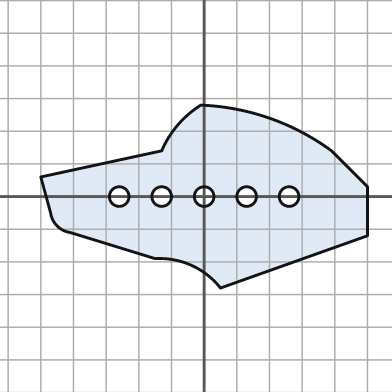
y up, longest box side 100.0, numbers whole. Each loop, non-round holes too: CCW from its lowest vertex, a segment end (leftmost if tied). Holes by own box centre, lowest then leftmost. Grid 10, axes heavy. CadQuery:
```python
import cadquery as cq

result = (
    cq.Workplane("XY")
    .moveTo(5.0, -28.0)
    .lineTo(50.0, -12.0)
    .lineTo(50.0, 3.0)
    .lineTo(39.0, 14.0)
    .threePointArc((20.0, 24.0), (-1.0, 28.0))
    .threePointArc((-8.0, 22.0), (-13.0, 14.0))
    .lineTo(-50.0, 6.0)
    .lineTo(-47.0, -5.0)
    .threePointArc((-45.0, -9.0), (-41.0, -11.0))
    .lineTo(-15.0, -19.0)
    .threePointArc((-4.0, -21.0), (5.0, -28.0))
    .close()
    .moveTo(-26.0, 0.0)
    .circle(3.0)
    .moveTo(-13.0, 0.0)
    .circle(3.0)
    .moveTo(0.0, 0.0)
    .circle(3.0)
    .moveTo(13.0, 0.0)
    .circle(3.0)
    .moveTo(26.0, 0.0)
    .circle(3.0)
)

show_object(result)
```